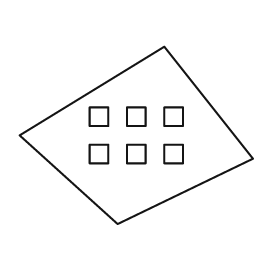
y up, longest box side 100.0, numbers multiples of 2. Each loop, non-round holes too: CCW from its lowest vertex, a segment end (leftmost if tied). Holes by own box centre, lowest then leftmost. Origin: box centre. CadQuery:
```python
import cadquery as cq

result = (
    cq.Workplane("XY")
    .moveTo(-8.0, -38.0)
    .lineTo(50.0, -10.0)
    .lineTo(12.0, 38.0)
    .lineTo(-50.0, 0.0)
    .close()
    .moveTo(-20.0, -12.0)
    .lineTo(-12.0, -12.0)
    .lineTo(-12.0, -4.0)
    .lineTo(-20.0, -4.0)
    .close()
    .moveTo(-4.0, -12.0)
    .lineTo(4.0, -12.0)
    .lineTo(4.0, -4.0)
    .lineTo(-4.0, -4.0)
    .close()
    .moveTo(12.0, -12.0)
    .lineTo(20.0, -12.0)
    .lineTo(20.0, -4.0)
    .lineTo(12.0, -4.0)
    .close()
    .moveTo(-20.0, 4.0)
    .lineTo(-12.0, 4.0)
    .lineTo(-12.0, 12.0)
    .lineTo(-20.0, 12.0)
    .close()
    .moveTo(-4.0, 4.0)
    .lineTo(4.0, 4.0)
    .lineTo(4.0, 12.0)
    .lineTo(-4.0, 12.0)
    .close()
    .moveTo(12.0, 4.0)
    .lineTo(20.0, 4.0)
    .lineTo(20.0, 12.0)
    .lineTo(12.0, 12.0)
    .close()
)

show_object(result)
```